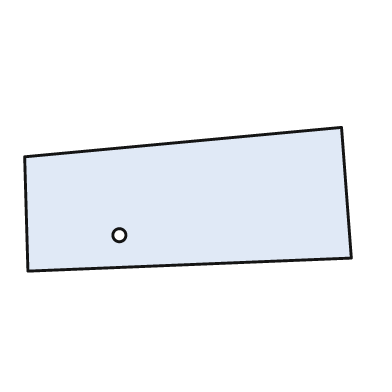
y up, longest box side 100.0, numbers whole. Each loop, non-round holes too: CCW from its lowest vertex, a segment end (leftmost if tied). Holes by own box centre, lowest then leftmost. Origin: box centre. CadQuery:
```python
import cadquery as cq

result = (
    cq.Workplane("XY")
    .moveTo(-49.0, -22.0)
    .lineTo(50.0, -18.0)
    .lineTo(47.0, 22.0)
    .lineTo(-50.0, 13.0)
    .close()
    .moveTo(-21.0, -11.0)
    .circle(2.0)
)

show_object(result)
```